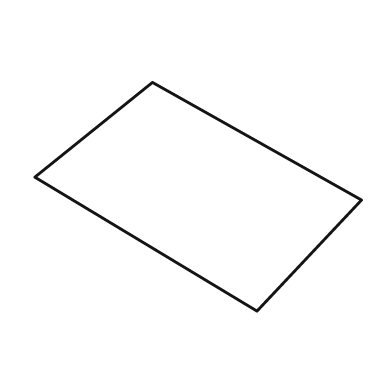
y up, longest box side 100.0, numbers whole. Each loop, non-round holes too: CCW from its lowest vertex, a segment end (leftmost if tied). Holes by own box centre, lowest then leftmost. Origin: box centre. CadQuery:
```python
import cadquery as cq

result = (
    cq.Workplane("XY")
    .moveTo(18.0, -35.0)
    .lineTo(50.0, -1.0)
    .lineTo(-14.0, 35.0)
    .lineTo(-50.0, 6.0)
    .close()
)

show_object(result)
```